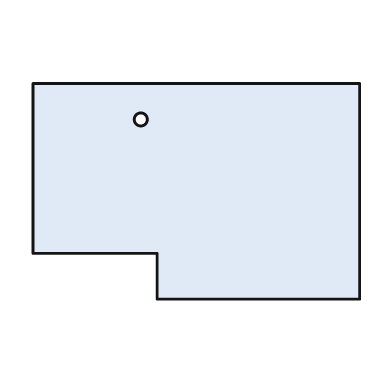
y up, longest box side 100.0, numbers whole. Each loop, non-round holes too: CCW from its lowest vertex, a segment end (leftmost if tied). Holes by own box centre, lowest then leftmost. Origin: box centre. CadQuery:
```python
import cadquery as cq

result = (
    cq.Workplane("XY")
    .moveTo(-12.0, -33.0)
    .lineTo(50.0, -33.0)
    .lineTo(50.0, 33.0)
    .lineTo(-50.0, 33.0)
    .lineTo(-50.0, -19.0)
    .lineTo(-12.0, -19.0)
    .close()
    .moveTo(-17.0, 22.0)
    .circle(2.0)
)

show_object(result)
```